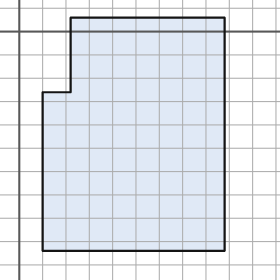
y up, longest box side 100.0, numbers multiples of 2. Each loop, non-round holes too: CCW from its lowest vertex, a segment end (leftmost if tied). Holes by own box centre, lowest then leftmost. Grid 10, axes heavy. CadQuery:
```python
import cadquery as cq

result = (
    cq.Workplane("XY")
    .moveTo(10.0, -94.0)
    .lineTo(88.0, -94.0)
    .lineTo(88.0, 6.0)
    .lineTo(22.0, 6.0)
    .lineTo(22.0, -26.0)
    .lineTo(10.0, -26.0)
    .close()
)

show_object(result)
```